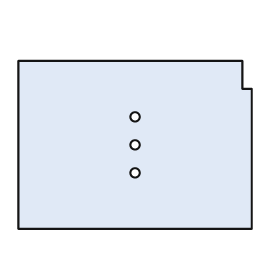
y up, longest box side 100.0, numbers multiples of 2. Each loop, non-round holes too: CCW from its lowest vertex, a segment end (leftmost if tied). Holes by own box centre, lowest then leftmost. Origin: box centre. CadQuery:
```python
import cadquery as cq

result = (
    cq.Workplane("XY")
    .moveTo(-50.0, -36.0)
    .lineTo(50.0, -36.0)
    .lineTo(50.0, 24.0)
    .lineTo(46.0, 24.0)
    .lineTo(46.0, 36.0)
    .lineTo(-50.0, 36.0)
    .close()
    .moveTo(0.0, -12.0)
    .circle(2.0)
    .moveTo(0.0, 0.0)
    .circle(2.0)
    .moveTo(0.0, 12.0)
    .circle(2.0)
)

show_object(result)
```